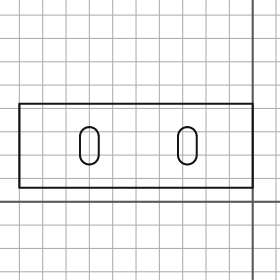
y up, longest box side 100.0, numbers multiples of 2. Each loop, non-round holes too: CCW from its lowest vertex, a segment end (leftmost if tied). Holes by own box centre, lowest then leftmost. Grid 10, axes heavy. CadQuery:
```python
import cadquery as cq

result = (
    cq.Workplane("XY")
    .moveTo(-100.0, 6.0)
    .lineTo(0.0, 6.0)
    .lineTo(0.0, 42.0)
    .lineTo(-100.0, 42.0)
    .close()
    .moveTo(-74.0, 20.0)
    .threePointArc((-70.0, 16.0), (-66.0, 20.0))
    .lineTo(-66.0, 28.0)
    .threePointArc((-70.0, 32.0), (-74.0, 28.0))
    .close()
    .moveTo(-32.0, 20.0)
    .threePointArc((-28.0, 16.0), (-24.0, 20.0))
    .lineTo(-24.0, 28.0)
    .threePointArc((-28.0, 32.0), (-32.0, 28.0))
    .close()
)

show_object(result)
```